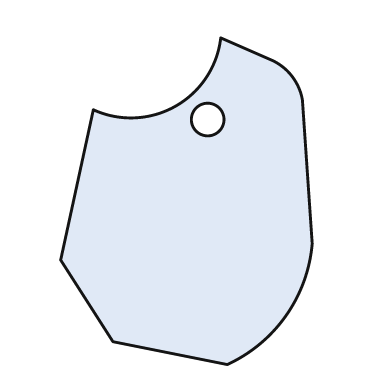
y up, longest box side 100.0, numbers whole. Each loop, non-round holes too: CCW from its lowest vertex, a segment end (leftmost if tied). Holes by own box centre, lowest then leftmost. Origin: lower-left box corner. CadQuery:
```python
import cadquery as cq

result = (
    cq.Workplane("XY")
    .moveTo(51.0, 0.0)
    .threePointArc((69.0, 15.0), (77.0, 37.0))
    .lineTo(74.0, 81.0)
    .threePointArc((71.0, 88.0), (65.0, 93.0))
    .lineTo(49.0, 100.0)
    .threePointArc((35.0, 79.0), (10.0, 78.0))
    .lineTo(0.0, 32.0)
    .lineTo(16.0, 7.0)
    .close()
    .moveTo(45.0, 75.0)
    .circle(5.0)
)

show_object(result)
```